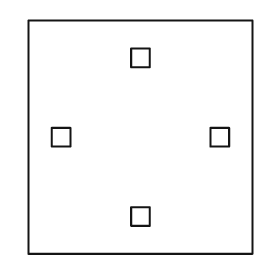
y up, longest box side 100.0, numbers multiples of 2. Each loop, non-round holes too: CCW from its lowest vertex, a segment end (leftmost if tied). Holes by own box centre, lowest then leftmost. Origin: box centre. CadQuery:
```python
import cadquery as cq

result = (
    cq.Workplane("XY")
    .moveTo(-48.0, -50.0)
    .lineTo(48.0, -50.0)
    .lineTo(48.0, 50.0)
    .lineTo(-48.0, 50.0)
    .close()
    .moveTo(-4.0, -38.0)
    .lineTo(4.0, -38.0)
    .lineTo(4.0, -30.0)
    .lineTo(-4.0, -30.0)
    .close()
    .moveTo(-38.0, -4.0)
    .lineTo(-30.0, -4.0)
    .lineTo(-30.0, 4.0)
    .lineTo(-38.0, 4.0)
    .close()
    .moveTo(30.0, -4.0)
    .lineTo(38.0, -4.0)
    .lineTo(38.0, 4.0)
    .lineTo(30.0, 4.0)
    .close()
    .moveTo(-4.0, 30.0)
    .lineTo(4.0, 30.0)
    .lineTo(4.0, 38.0)
    .lineTo(-4.0, 38.0)
    .close()
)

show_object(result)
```